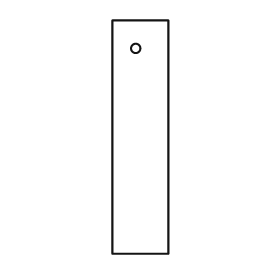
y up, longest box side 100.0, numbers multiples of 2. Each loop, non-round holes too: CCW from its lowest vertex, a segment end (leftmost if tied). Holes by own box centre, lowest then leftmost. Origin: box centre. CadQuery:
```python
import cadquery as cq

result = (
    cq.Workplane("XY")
    .moveTo(-12.0, -50.0)
    .lineTo(12.0, -50.0)
    .lineTo(12.0, 50.0)
    .lineTo(-12.0, 50.0)
    .close()
    .moveTo(-2.0, 38.0)
    .circle(2.0)
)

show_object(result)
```